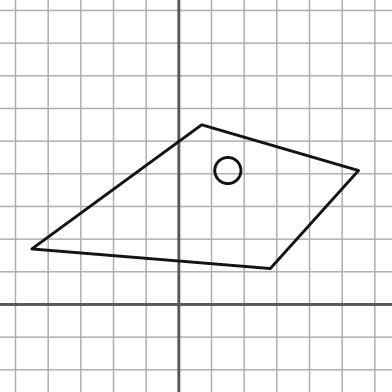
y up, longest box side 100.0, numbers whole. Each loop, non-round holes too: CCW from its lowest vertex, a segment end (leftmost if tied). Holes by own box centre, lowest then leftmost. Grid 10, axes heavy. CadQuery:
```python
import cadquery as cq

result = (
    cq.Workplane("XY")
    .moveTo(28.0, 11.0)
    .lineTo(55.0, 41.0)
    .lineTo(7.0, 55.0)
    .lineTo(-45.0, 17.0)
    .close()
    .moveTo(15.0, 41.0)
    .circle(4.0)
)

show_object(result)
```